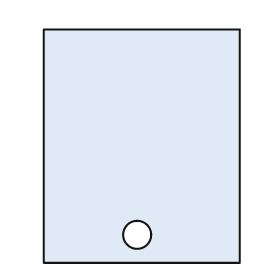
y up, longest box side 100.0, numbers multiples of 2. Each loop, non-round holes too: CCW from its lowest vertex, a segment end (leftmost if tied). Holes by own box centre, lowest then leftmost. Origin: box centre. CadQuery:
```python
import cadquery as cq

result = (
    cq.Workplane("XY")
    .moveTo(-42.0, -50.0)
    .lineTo(42.0, -50.0)
    .lineTo(42.0, 50.0)
    .lineTo(-42.0, 50.0)
    .close()
    .moveTo(-2.0, -38.0)
    .circle(6.0)
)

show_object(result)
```